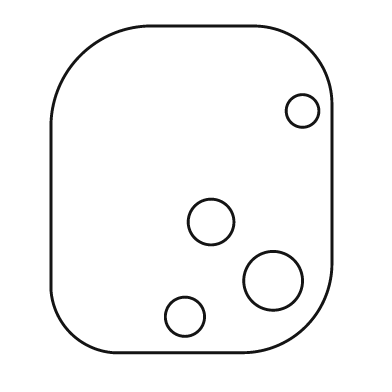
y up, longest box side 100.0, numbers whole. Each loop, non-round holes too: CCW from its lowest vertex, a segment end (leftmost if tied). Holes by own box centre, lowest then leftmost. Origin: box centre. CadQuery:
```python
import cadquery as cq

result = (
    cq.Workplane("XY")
    .moveTo(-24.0, -50.0)
    .lineTo(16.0, -50.0)
    .threePointArc((35.0, -42.0), (43.0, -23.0))
    .lineTo(43.0, 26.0)
    .threePointArc((36.0, 43.0), (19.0, 50.0))
    .lineTo(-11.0, 50.0)
    .threePointArc((-34.0, 41.0), (-43.0, 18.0))
    .lineTo(-43.0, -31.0)
    .threePointArc((-37.0, -44.0), (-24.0, -50.0))
    .close()
    .moveTo(-2.0, -39.0)
    .circle(6.0)
    .moveTo(25.0, -28.0)
    .circle(9.0)
    .moveTo(6.0, -10.0)
    .circle(7.0)
    .moveTo(34.0, 24.0)
    .circle(5.0)
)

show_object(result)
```